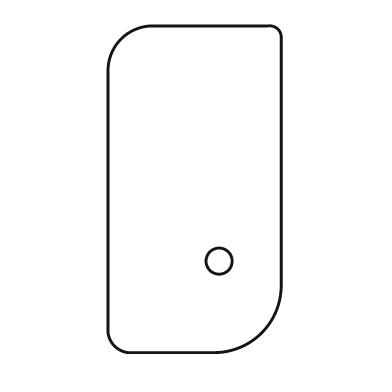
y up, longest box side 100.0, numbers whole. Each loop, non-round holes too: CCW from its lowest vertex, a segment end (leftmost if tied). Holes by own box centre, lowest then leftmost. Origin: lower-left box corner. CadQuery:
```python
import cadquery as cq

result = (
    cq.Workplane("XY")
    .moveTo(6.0, 0.0)
    .lineTo(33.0, 0.0)
    .threePointArc((47.0, 6.0), (53.0, 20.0))
    .lineTo(53.0, 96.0)
    .threePointArc((52.0, 99.0), (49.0, 100.0))
    .lineTo(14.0, 100.0)
    .threePointArc((4.0, 96.0), (0.0, 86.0))
    .lineTo(0.0, 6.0)
    .threePointArc((2.0, 2.0), (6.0, 0.0))
    .close()
    .moveTo(34.0, 28.0)
    .circle(4.0)
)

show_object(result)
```